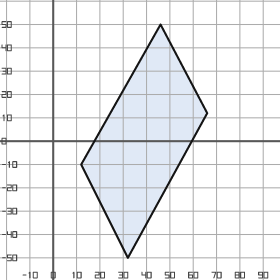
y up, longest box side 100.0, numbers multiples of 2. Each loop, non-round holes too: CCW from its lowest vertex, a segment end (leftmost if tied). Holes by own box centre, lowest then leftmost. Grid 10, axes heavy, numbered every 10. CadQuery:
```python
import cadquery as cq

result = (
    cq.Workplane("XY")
    .moveTo(32.0, -50.0)
    .lineTo(66.0, 12.0)
    .lineTo(46.0, 50.0)
    .lineTo(12.0, -10.0)
    .close()
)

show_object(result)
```